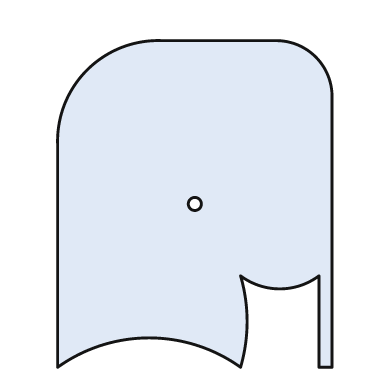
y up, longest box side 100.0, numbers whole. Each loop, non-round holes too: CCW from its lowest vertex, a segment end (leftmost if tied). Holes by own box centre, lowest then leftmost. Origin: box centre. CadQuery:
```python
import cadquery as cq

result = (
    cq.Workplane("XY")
    .moveTo(-42.0, -50.0)
    .threePointArc((-14.0, -41.0), (14.0, -50.0))
    .threePointArc((16.0, -36.0), (14.0, -22.0))
    .threePointArc((26.0, -26.0), (38.0, -22.0))
    .lineTo(38.0, -50.0)
    .lineTo(42.0, -50.0)
    .lineTo(42.0, 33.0)
    .threePointArc((37.0, 45.0), (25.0, 50.0))
    .lineTo(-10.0, 50.0)
    .threePointArc((-33.0, 41.0), (-42.0, 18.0))
    .close()
    .moveTo(0.0, 0.0)
    .circle(2.0)
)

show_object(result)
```